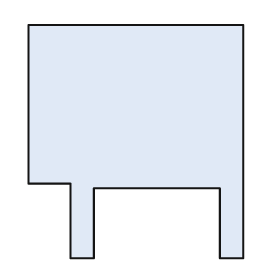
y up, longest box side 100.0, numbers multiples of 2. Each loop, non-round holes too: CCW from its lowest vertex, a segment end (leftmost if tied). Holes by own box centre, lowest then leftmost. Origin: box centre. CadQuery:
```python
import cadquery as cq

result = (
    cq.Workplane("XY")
    .moveTo(-28.0, -50.0)
    .lineTo(-18.0, -50.0)
    .lineTo(-18.0, -20.0)
    .lineTo(36.0, -20.0)
    .lineTo(36.0, -50.0)
    .lineTo(46.0, -50.0)
    .lineTo(46.0, 50.0)
    .lineTo(-46.0, 50.0)
    .lineTo(-46.0, -18.0)
    .lineTo(-28.0, -18.0)
    .close()
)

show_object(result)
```